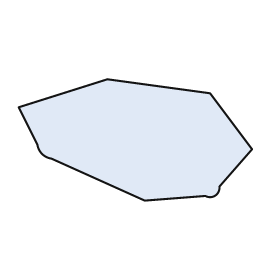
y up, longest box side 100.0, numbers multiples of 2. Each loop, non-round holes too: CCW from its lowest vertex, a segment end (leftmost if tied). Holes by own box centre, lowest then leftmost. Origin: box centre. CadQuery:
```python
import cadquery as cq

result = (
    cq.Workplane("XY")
    .moveTo(4.0, -26.0)
    .lineTo(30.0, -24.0)
    .threePointArc((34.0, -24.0), (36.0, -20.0))
    .lineTo(50.0, -4.0)
    .lineTo(32.0, 20.0)
    .lineTo(-12.0, 26.0)
    .lineTo(-50.0, 14.0)
    .lineTo(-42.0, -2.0)
    .threePointArc((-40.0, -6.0), (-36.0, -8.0))
    .close()
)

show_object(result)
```